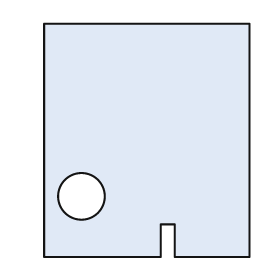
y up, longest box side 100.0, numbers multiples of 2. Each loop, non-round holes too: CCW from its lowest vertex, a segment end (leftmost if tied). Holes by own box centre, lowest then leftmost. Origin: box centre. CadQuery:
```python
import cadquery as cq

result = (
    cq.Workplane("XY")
    .moveTo(-44.0, -50.0)
    .lineTo(6.0, -50.0)
    .lineTo(6.0, -36.0)
    .lineTo(12.0, -36.0)
    .lineTo(12.0, -50.0)
    .lineTo(44.0, -50.0)
    .lineTo(44.0, 50.0)
    .lineTo(-44.0, 50.0)
    .close()
    .moveTo(-28.0, -24.0)
    .circle(10.0)
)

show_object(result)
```